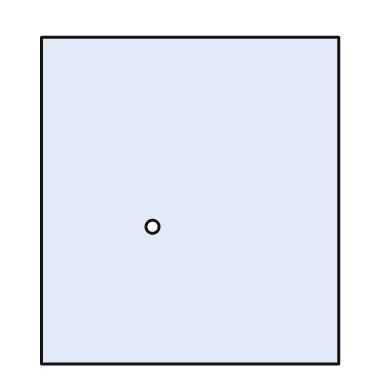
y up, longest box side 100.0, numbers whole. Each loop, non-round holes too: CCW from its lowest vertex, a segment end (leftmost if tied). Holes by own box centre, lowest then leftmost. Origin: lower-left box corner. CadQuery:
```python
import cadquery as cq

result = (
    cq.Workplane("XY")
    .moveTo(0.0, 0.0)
    .lineTo(91.0, 0.0)
    .lineTo(91.0, 100.0)
    .lineTo(0.0, 100.0)
    .close()
    .moveTo(34.0, 42.0)
    .circle(2.0)
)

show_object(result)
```